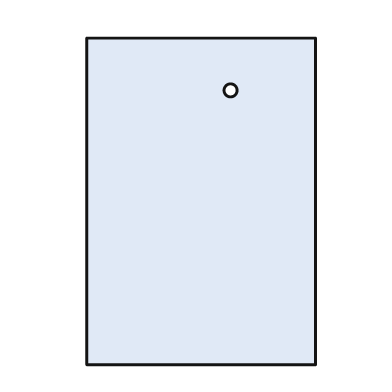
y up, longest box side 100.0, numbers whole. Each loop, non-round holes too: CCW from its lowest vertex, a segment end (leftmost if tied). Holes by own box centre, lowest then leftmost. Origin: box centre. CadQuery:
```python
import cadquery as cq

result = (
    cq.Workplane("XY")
    .moveTo(-35.0, -50.0)
    .lineTo(35.0, -50.0)
    .lineTo(35.0, 50.0)
    .lineTo(-35.0, 50.0)
    .close()
    .moveTo(9.0, 34.0)
    .circle(2.0)
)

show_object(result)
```